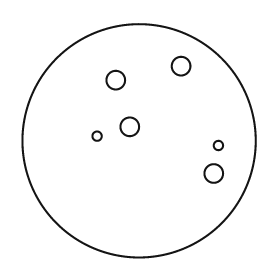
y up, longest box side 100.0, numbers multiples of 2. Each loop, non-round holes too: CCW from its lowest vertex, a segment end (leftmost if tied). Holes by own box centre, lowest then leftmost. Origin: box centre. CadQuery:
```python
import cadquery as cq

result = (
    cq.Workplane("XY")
    .moveTo(0.0, 0.0)
    .circle(50.0)
    .moveTo(32.0, -14.0)
    .circle(4.0)
    .moveTo(34.0, -2.0)
    .circle(2.0)
    .moveTo(-18.0, 2.0)
    .circle(2.0)
    .moveTo(-4.0, 6.0)
    .circle(4.0)
    .moveTo(-10.0, 26.0)
    .circle(4.0)
    .moveTo(18.0, 32.0)
    .circle(4.0)
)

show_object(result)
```